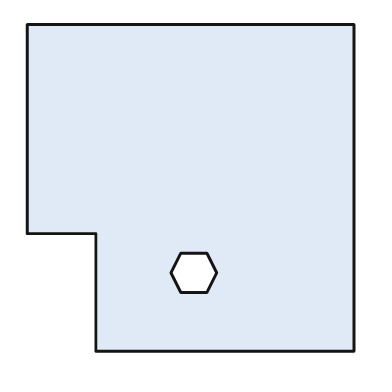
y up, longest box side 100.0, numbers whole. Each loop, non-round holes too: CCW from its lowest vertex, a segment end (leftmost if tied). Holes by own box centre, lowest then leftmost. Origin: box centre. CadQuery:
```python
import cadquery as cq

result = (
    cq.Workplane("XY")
    .moveTo(-29.0, -50.0)
    .lineTo(50.0, -50.0)
    .lineTo(50.0, 50.0)
    .lineTo(-50.0, 50.0)
    .lineTo(-50.0, -14.0)
    .lineTo(-29.0, -14.0)
    .close()
    .moveTo(-3.0, -32.0)
    .lineTo(5.0, -32.0)
    .lineTo(8.0, -26.0)
    .lineTo(5.0, -20.0)
    .lineTo(-3.0, -20.0)
    .lineTo(-6.0, -26.0)
    .close()
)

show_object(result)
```